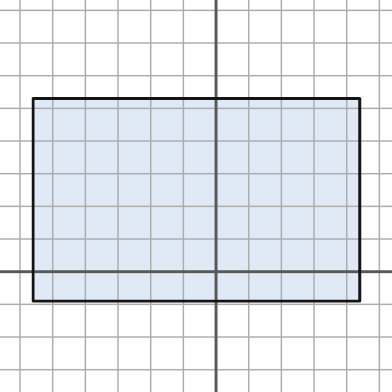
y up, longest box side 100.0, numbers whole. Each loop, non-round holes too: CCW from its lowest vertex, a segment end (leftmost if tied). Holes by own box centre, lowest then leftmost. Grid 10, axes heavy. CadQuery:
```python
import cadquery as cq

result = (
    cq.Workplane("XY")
    .moveTo(-56.0, -9.0)
    .lineTo(44.0, -9.0)
    .lineTo(44.0, 53.0)
    .lineTo(-56.0, 53.0)
    .close()
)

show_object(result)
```